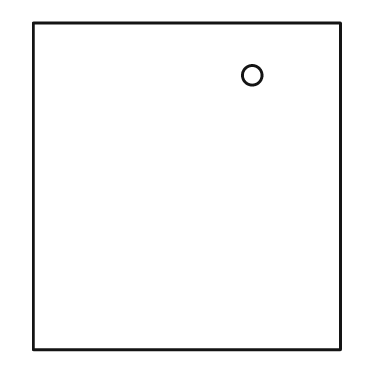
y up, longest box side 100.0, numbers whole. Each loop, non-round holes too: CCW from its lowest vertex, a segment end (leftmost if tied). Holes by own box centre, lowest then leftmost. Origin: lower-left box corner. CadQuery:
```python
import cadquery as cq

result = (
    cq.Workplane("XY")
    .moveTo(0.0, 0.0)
    .lineTo(94.0, 0.0)
    .lineTo(94.0, 100.0)
    .lineTo(0.0, 100.0)
    .close()
    .moveTo(67.0, 84.0)
    .circle(3.0)
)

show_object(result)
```